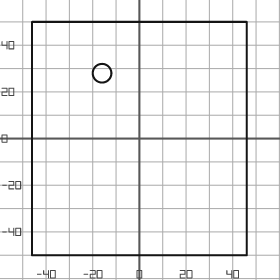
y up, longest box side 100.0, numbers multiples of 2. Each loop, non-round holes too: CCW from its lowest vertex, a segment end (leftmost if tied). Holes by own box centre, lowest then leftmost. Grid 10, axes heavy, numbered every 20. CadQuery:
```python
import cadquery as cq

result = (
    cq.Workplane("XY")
    .moveTo(-46.0, -50.0)
    .lineTo(46.0, -50.0)
    .lineTo(46.0, 50.0)
    .lineTo(-46.0, 50.0)
    .close()
    .moveTo(-16.0, 28.0)
    .circle(4.0)
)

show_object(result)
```